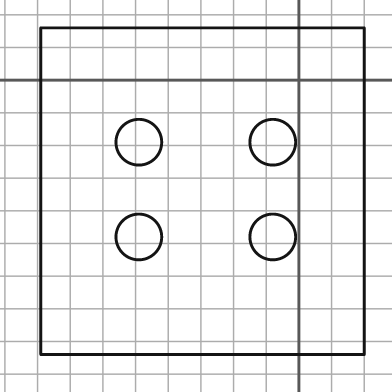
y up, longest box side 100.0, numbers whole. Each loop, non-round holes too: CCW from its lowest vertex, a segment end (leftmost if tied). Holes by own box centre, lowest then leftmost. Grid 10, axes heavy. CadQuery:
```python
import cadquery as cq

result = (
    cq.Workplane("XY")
    .moveTo(-79.0, -84.0)
    .lineTo(20.0, -84.0)
    .lineTo(20.0, 16.0)
    .lineTo(-79.0, 16.0)
    .close()
    .moveTo(-49.0, -48.0)
    .circle(7.0)
    .moveTo(-8.0, -48.0)
    .circle(7.0)
    .moveTo(-49.0, -19.0)
    .circle(7.0)
    .moveTo(-8.0, -19.0)
    .circle(7.0)
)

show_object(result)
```